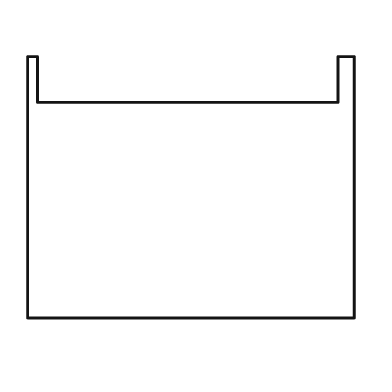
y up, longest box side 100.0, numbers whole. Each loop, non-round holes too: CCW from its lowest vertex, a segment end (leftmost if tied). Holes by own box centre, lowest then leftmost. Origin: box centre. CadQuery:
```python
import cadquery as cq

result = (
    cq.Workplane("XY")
    .moveTo(-50.0, -40.0)
    .lineTo(50.0, -40.0)
    .lineTo(50.0, 40.0)
    .lineTo(45.0, 40.0)
    .lineTo(45.0, 26.0)
    .lineTo(-47.0, 26.0)
    .lineTo(-47.0, 40.0)
    .lineTo(-50.0, 40.0)
    .close()
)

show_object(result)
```